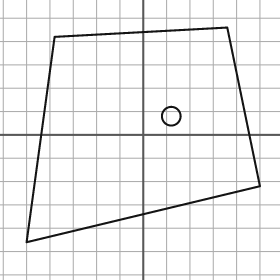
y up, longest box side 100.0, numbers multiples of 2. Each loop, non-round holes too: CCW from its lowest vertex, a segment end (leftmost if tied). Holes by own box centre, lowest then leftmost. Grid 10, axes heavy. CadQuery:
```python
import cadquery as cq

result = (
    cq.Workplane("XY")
    .moveTo(-50.0, -46.0)
    .lineTo(50.0, -22.0)
    .lineTo(36.0, 46.0)
    .lineTo(-38.0, 42.0)
    .close()
    .moveTo(12.0, 8.0)
    .circle(4.0)
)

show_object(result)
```